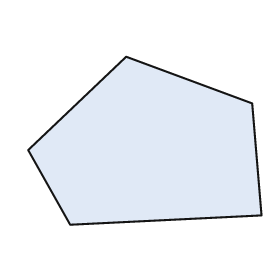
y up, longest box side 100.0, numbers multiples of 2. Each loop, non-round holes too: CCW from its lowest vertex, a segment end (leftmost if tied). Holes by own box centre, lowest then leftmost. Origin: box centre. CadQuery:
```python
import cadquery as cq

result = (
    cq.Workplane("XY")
    .moveTo(-32.0, -36.0)
    .lineTo(50.0, -32.0)
    .lineTo(46.0, 16.0)
    .lineTo(-8.0, 36.0)
    .lineTo(-50.0, -4.0)
    .close()
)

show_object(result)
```